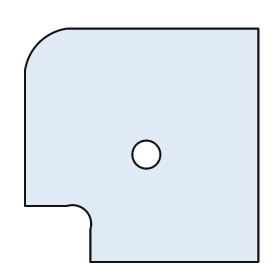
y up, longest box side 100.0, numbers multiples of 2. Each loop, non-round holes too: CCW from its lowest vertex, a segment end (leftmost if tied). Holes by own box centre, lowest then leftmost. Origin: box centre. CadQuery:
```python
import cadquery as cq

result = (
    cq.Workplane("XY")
    .moveTo(-22.0, -50.0)
    .lineTo(50.0, -50.0)
    .lineTo(50.0, 50.0)
    .lineTo(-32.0, 50.0)
    .threePointArc((-44.0, 44.0), (-50.0, 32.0))
    .lineTo(-50.0, -26.0)
    .lineTo(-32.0, -26.0)
    .threePointArc((-24.0, -28.0), (-22.0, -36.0))
    .close()
    .moveTo(2.0, -4.0)
    .circle(6.0)
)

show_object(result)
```